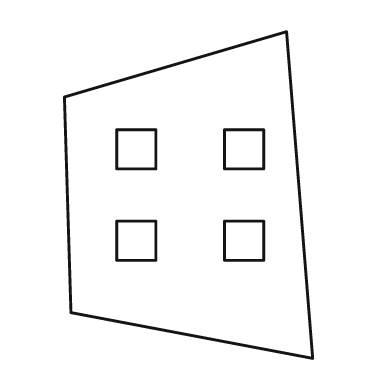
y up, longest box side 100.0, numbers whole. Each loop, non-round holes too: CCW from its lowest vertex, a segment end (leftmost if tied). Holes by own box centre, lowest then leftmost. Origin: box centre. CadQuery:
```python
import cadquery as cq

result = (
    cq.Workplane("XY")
    .moveTo(38.0, -50.0)
    .lineTo(30.0, 50.0)
    .lineTo(-38.0, 30.0)
    .lineTo(-36.0, -36.0)
    .close()
    .moveTo(-22.0, -20.0)
    .lineTo(-10.0, -20.0)
    .lineTo(-10.0, -8.0)
    .lineTo(-22.0, -8.0)
    .close()
    .moveTo(11.0, -20.0)
    .lineTo(23.0, -20.0)
    .lineTo(23.0, -8.0)
    .lineTo(11.0, -8.0)
    .close()
    .moveTo(-22.0, 8.0)
    .lineTo(-10.0, 8.0)
    .lineTo(-10.0, 20.0)
    .lineTo(-22.0, 20.0)
    .close()
    .moveTo(11.0, 8.0)
    .lineTo(23.0, 8.0)
    .lineTo(23.0, 20.0)
    .lineTo(11.0, 20.0)
    .close()
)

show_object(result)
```